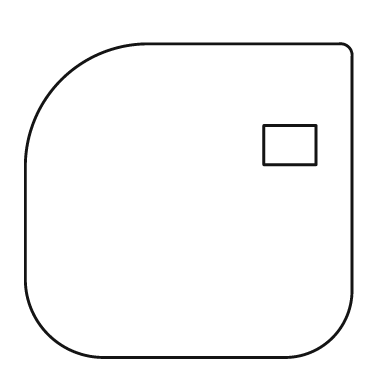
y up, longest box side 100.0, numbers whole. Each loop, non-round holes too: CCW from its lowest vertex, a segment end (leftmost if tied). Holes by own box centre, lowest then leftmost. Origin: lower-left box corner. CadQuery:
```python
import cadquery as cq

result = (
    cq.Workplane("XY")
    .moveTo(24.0, 0.0)
    .lineTo(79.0, 0.0)
    .threePointArc((94.0, 6.0), (100.0, 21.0))
    .lineTo(100.0, 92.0)
    .threePointArc((99.0, 95.0), (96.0, 96.0))
    .lineTo(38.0, 96.0)
    .threePointArc((11.0, 85.0), (0.0, 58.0))
    .lineTo(0.0, 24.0)
    .threePointArc((7.0, 7.0), (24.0, 0.0))
    .close()
    .moveTo(73.0, 59.0)
    .lineTo(89.0, 59.0)
    .lineTo(89.0, 71.0)
    .lineTo(73.0, 71.0)
    .close()
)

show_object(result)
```